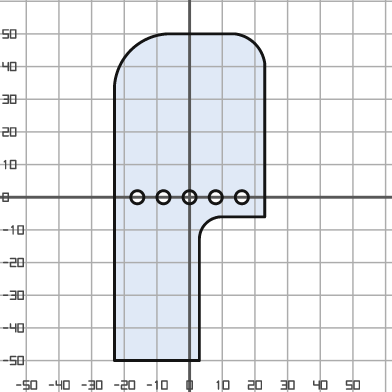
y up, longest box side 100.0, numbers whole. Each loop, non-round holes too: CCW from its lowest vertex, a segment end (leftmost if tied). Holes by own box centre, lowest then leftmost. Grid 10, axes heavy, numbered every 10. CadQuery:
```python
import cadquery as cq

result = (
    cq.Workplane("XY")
    .moveTo(-23.0, -50.0)
    .lineTo(3.0, -50.0)
    .lineTo(3.0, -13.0)
    .threePointArc((5.0, -8.0), (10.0, -6.0))
    .lineTo(23.0, -6.0)
    .lineTo(23.0, 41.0)
    .threePointArc((20.0, 47.0), (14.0, 50.0))
    .lineTo(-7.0, 50.0)
    .threePointArc((-18.0, 45.0), (-23.0, 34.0))
    .close()
    .moveTo(-16.0, 0.0)
    .circle(2.0)
    .moveTo(-8.0, 0.0)
    .circle(2.0)
    .moveTo(0.0, 0.0)
    .circle(2.0)
    .moveTo(8.0, 0.0)
    .circle(2.0)
    .moveTo(16.0, 0.0)
    .circle(2.0)
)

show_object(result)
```